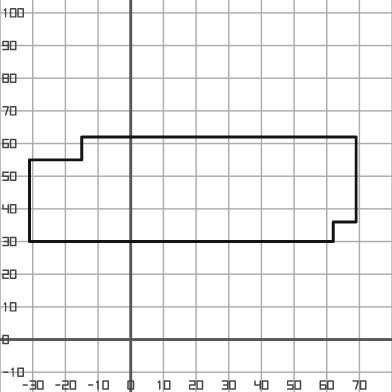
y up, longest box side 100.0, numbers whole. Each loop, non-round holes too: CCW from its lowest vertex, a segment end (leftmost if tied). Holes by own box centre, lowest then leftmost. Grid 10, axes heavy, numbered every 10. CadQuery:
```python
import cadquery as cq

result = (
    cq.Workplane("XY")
    .moveTo(-31.0, 30.0)
    .lineTo(62.0, 30.0)
    .lineTo(62.0, 36.0)
    .lineTo(69.0, 36.0)
    .lineTo(69.0, 62.0)
    .lineTo(-15.0, 62.0)
    .lineTo(-15.0, 55.0)
    .lineTo(-31.0, 55.0)
    .close()
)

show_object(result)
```